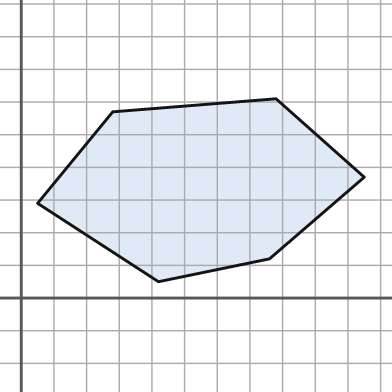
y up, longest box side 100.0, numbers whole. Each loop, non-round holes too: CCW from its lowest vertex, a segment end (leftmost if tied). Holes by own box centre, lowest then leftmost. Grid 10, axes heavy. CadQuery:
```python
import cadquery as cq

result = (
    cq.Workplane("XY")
    .moveTo(42.0, 5.0)
    .lineTo(76.0, 12.0)
    .lineTo(105.0, 37.0)
    .lineTo(78.0, 61.0)
    .lineTo(28.0, 57.0)
    .lineTo(5.0, 29.0)
    .close()
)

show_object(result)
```